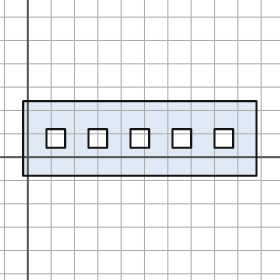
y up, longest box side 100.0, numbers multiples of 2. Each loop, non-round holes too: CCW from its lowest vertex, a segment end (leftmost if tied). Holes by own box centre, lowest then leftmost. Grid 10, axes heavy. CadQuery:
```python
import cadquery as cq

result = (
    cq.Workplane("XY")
    .moveTo(-2.0, -8.0)
    .lineTo(98.0, -8.0)
    .lineTo(98.0, 24.0)
    .lineTo(-2.0, 24.0)
    .close()
    .moveTo(8.0, 4.0)
    .lineTo(16.0, 4.0)
    .lineTo(16.0, 12.0)
    .lineTo(8.0, 12.0)
    .close()
    .moveTo(26.0, 4.0)
    .lineTo(34.0, 4.0)
    .lineTo(34.0, 12.0)
    .lineTo(26.0, 12.0)
    .close()
    .moveTo(44.0, 4.0)
    .lineTo(52.0, 4.0)
    .lineTo(52.0, 12.0)
    .lineTo(44.0, 12.0)
    .close()
    .moveTo(62.0, 4.0)
    .lineTo(70.0, 4.0)
    .lineTo(70.0, 12.0)
    .lineTo(62.0, 12.0)
    .close()
    .moveTo(80.0, 4.0)
    .lineTo(88.0, 4.0)
    .lineTo(88.0, 12.0)
    .lineTo(80.0, 12.0)
    .close()
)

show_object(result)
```